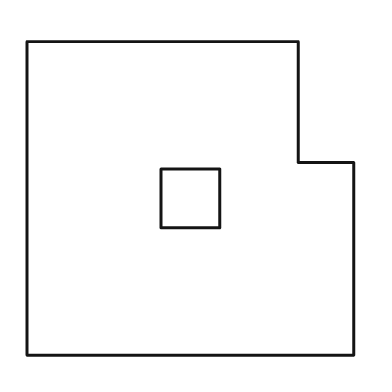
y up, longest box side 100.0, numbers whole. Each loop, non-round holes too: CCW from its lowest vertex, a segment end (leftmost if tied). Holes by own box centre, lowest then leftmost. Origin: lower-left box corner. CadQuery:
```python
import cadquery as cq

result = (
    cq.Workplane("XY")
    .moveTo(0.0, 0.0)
    .lineTo(100.0, 0.0)
    .lineTo(100.0, 59.0)
    .lineTo(83.0, 59.0)
    .lineTo(83.0, 96.0)
    .lineTo(0.0, 96.0)
    .close()
    .moveTo(41.0, 39.0)
    .lineTo(59.0, 39.0)
    .lineTo(59.0, 57.0)
    .lineTo(41.0, 57.0)
    .close()
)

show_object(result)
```